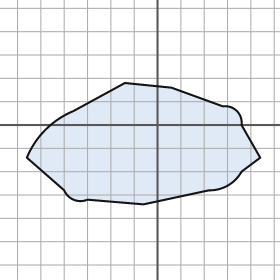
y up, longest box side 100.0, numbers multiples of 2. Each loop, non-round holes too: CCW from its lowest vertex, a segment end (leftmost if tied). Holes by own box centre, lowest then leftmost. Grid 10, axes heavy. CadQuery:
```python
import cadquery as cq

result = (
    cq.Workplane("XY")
    .moveTo(-6.0, -34.0)
    .lineTo(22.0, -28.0)
    .threePointArc((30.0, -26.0), (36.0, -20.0))
    .lineTo(44.0, -14.0)
    .lineTo(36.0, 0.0)
    .threePointArc((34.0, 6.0), (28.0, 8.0))
    .lineTo(6.0, 16.0)
    .lineTo(-14.0, 18.0)
    .lineTo(-36.0, 6.0)
    .threePointArc((-48.0, -2.0), (-56.0, -14.0))
    .lineTo(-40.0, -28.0)
    .threePointArc((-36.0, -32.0), (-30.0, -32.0))
    .close()
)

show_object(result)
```